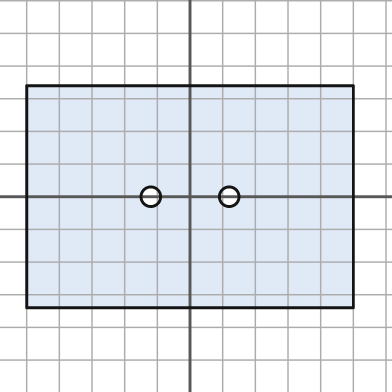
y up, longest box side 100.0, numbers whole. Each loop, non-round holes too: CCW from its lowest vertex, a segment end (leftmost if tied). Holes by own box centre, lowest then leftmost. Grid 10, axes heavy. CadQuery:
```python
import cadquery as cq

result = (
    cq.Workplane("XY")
    .moveTo(-50.0, -34.0)
    .lineTo(50.0, -34.0)
    .lineTo(50.0, 34.0)
    .lineTo(-50.0, 34.0)
    .close()
    .moveTo(-12.0, 0.0)
    .circle(3.0)
    .moveTo(12.0, 0.0)
    .circle(3.0)
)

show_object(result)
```